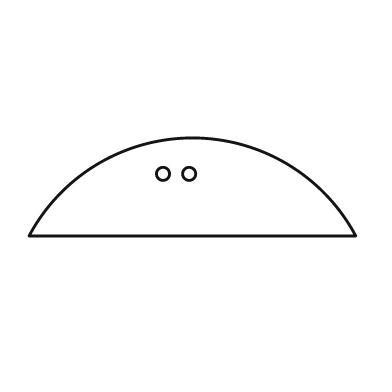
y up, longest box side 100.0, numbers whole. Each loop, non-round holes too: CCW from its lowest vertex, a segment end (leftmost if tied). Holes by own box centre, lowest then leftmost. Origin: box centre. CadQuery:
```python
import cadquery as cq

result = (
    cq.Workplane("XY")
    .moveTo(-50.0, -15.0)
    .lineTo(50.0, -15.0)
    .threePointArc((0.0, 15.0), (-50.0, -15.0))
    .close()
    .moveTo(-9.0, 4.0)
    .circle(2.0)
    .moveTo(-1.0, 4.0)
    .circle(2.0)
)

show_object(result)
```